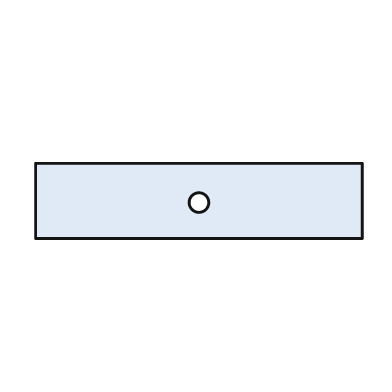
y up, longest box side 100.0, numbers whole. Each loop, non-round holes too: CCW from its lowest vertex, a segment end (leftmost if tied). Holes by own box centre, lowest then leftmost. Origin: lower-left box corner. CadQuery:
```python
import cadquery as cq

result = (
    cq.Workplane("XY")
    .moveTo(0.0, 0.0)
    .lineTo(100.0, 0.0)
    .lineTo(100.0, 23.0)
    .lineTo(0.0, 23.0)
    .close()
    .moveTo(50.0, 11.0)
    .circle(3.0)
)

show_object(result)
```